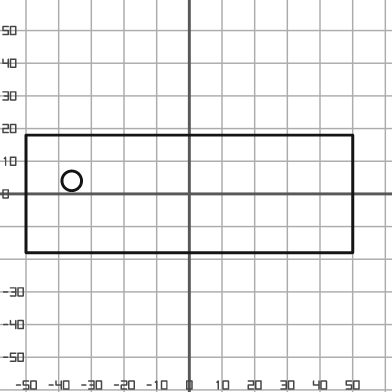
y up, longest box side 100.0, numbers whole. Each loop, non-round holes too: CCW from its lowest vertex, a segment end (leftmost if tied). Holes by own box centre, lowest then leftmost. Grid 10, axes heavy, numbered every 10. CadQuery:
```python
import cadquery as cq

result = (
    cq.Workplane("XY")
    .moveTo(-50.0, -18.0)
    .lineTo(50.0, -18.0)
    .lineTo(50.0, 18.0)
    .lineTo(-50.0, 18.0)
    .close()
    .moveTo(-36.0, 4.0)
    .circle(3.0)
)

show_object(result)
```